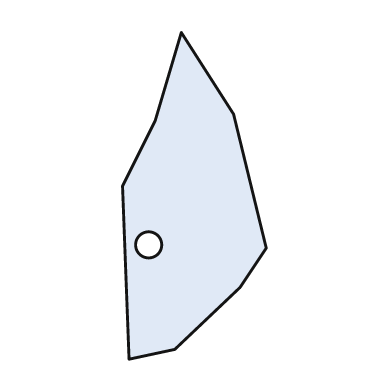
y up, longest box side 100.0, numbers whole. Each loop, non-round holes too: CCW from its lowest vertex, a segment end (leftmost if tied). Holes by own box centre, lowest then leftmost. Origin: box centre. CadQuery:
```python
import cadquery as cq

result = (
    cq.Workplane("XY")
    .moveTo(-20.0, -50.0)
    .lineTo(-6.0, -47.0)
    .lineTo(14.0, -28.0)
    .lineTo(22.0, -16.0)
    .lineTo(12.0, 25.0)
    .lineTo(-4.0, 50.0)
    .lineTo(-12.0, 23.0)
    .lineTo(-22.0, 3.0)
    .close()
    .moveTo(-14.0, -15.0)
    .circle(4.0)
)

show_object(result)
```